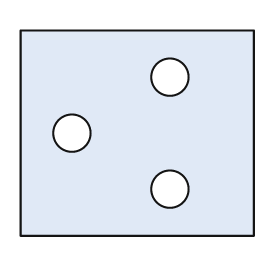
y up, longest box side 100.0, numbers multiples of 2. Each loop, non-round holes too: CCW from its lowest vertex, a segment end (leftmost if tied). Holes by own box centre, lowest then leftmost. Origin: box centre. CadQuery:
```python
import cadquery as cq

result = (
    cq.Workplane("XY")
    .moveTo(-50.0, -44.0)
    .lineTo(50.0, -44.0)
    .lineTo(50.0, 44.0)
    .lineTo(-50.0, 44.0)
    .close()
    .moveTo(14.0, -24.0)
    .circle(8.0)
    .moveTo(-28.0, 0.0)
    .circle(8.0)
    .moveTo(14.0, 24.0)
    .circle(8.0)
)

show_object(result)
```